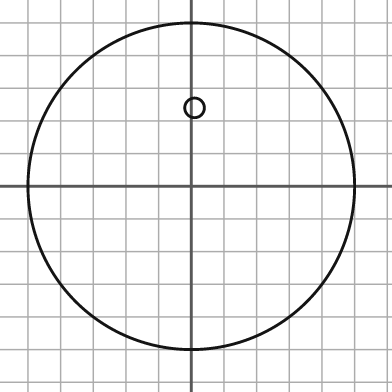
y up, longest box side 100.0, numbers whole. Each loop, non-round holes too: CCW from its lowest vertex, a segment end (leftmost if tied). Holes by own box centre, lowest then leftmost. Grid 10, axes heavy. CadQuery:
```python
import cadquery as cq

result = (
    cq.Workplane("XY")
    .moveTo(0.0, 0.0)
    .circle(50.0)
    .moveTo(1.0, 24.0)
    .circle(3.0)
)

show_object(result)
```